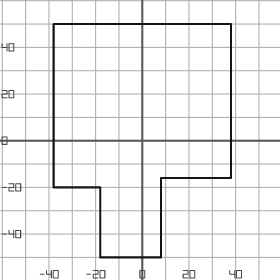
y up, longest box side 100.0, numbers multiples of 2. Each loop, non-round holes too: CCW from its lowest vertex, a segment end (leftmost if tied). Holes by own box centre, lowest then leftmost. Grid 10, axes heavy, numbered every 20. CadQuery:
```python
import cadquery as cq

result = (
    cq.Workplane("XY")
    .moveTo(-18.0, -50.0)
    .lineTo(8.0, -50.0)
    .lineTo(8.0, -16.0)
    .lineTo(38.0, -16.0)
    .lineTo(38.0, 50.0)
    .lineTo(-38.0, 50.0)
    .lineTo(-38.0, -20.0)
    .lineTo(-18.0, -20.0)
    .close()
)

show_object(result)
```